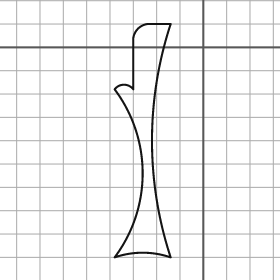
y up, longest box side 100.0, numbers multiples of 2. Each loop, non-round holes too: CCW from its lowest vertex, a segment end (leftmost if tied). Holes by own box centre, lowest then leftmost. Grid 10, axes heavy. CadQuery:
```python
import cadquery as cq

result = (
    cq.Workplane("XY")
    .moveTo(-38.0, -90.0)
    .threePointArc((-26.0, -88.0), (-14.0, -90.0))
    .threePointArc((-22.0, -40.0), (-14.0, 10.0))
    .lineTo(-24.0, 10.0)
    .threePointArc((-28.0, 8.0), (-30.0, 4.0))
    .lineTo(-30.0, -18.0)
    .threePointArc((-34.0, -16.0), (-38.0, -18.0))
    .threePointArc((-26.0, -54.0), (-38.0, -90.0))
    .close()
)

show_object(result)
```